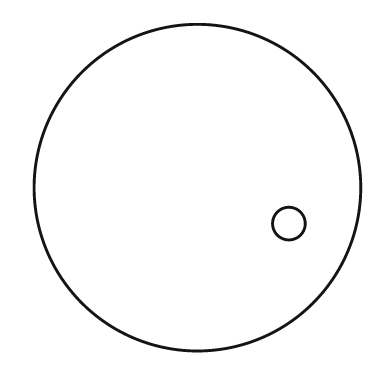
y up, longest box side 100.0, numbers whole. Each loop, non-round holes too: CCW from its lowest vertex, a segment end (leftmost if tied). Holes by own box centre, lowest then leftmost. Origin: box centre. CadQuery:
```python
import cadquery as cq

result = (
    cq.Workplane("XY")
    .moveTo(0.0, 0.0)
    .circle(50.0)
    .moveTo(28.0, -11.0)
    .circle(5.0)
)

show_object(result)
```